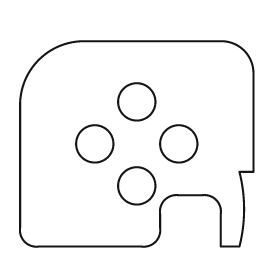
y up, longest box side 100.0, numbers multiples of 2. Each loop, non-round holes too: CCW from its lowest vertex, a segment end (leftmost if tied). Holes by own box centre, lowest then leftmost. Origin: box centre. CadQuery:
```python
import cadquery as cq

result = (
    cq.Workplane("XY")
    .moveTo(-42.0, -44.0)
    .lineTo(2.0, -44.0)
    .threePointArc((8.0, -42.0), (10.0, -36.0))
    .lineTo(10.0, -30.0)
    .threePointArc((12.0, -24.0), (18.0, -22.0))
    .lineTo(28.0, -22.0)
    .threePointArc((34.0, -24.0), (36.0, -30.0))
    .lineTo(36.0, -44.0)
    .lineTo(44.0, -44.0)
    .threePointArc((46.0, -28.0), (44.0, -12.0))
    .lineTo(50.0, -12.0)
    .lineTo(50.0, 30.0)
    .threePointArc((46.0, 40.0), (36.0, 44.0))
    .lineTo(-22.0, 44.0)
    .threePointArc((-42.0, 36.0), (-50.0, 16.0))
    .lineTo(-50.0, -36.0)
    .threePointArc((-48.0, -42.0), (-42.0, -44.0))
    .close()
    .moveTo(0.0, -18.0)
    .circle(8.0)
    .moveTo(-18.0, 0.0)
    .circle(8.0)
    .moveTo(18.0, 0.0)
    .circle(8.0)
    .moveTo(0.0, 18.0)
    .circle(8.0)
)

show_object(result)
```